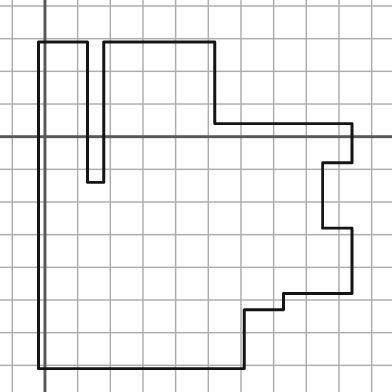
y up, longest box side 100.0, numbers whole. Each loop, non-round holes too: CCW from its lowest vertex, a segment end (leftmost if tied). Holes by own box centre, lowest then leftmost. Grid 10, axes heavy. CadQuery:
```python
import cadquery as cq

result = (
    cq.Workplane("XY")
    .moveTo(-2.0, -71.0)
    .lineTo(61.0, -71.0)
    .lineTo(61.0, -53.0)
    .lineTo(73.0, -53.0)
    .lineTo(73.0, -48.0)
    .lineTo(94.0, -48.0)
    .lineTo(94.0, -28.0)
    .lineTo(85.0, -28.0)
    .lineTo(85.0, -8.0)
    .lineTo(94.0, -8.0)
    .lineTo(94.0, 4.0)
    .lineTo(52.0, 4.0)
    .lineTo(52.0, 29.0)
    .lineTo(18.0, 29.0)
    .lineTo(18.0, -14.0)
    .lineTo(13.0, -14.0)
    .lineTo(13.0, 29.0)
    .lineTo(-2.0, 29.0)
    .close()
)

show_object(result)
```